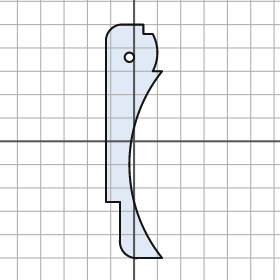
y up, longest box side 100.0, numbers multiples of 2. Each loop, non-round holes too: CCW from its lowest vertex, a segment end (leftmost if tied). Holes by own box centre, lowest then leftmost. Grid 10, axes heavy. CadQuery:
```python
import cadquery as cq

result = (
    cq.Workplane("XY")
    .moveTo(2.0, -50.0)
    .lineTo(12.0, -50.0)
    .threePointArc((-2.0, -10.0), (12.0, 30.0))
    .lineTo(8.0, 30.0)
    .threePointArc((10.0, 38.0), (8.0, 46.0))
    .lineTo(4.0, 46.0)
    .lineTo(4.0, 50.0)
    .lineTo(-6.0, 50.0)
    .threePointArc((-10.0, 48.0), (-12.0, 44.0))
    .lineTo(-12.0, -26.0)
    .lineTo(-6.0, -26.0)
    .lineTo(-6.0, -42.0)
    .threePointArc((-4.0, -48.0), (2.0, -50.0))
    .close()
    .moveTo(-2.0, 36.0)
    .circle(2.0)
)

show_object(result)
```